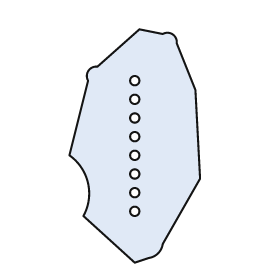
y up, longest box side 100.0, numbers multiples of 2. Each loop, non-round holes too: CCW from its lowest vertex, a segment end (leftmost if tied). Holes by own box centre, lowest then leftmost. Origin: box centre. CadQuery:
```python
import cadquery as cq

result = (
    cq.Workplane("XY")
    .moveTo(0.0, -50.0)
    .lineTo(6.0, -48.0)
    .threePointArc((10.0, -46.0), (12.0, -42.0))
    .lineTo(28.0, -14.0)
    .lineTo(26.0, 24.0)
    .lineTo(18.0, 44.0)
    .threePointArc((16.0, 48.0), (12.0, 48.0))
    .lineTo(2.0, 50.0)
    .lineTo(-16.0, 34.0)
    .threePointArc((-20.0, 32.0), (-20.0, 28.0))
    .lineTo(-28.0, -4.0)
    .threePointArc((-20.0, -16.0), (-22.0, -30.0))
    .close()
    .moveTo(0.0, -28.0)
    .circle(2.0)
    .moveTo(0.0, -20.0)
    .circle(2.0)
    .moveTo(0.0, -12.0)
    .circle(2.0)
    .moveTo(0.0, -4.0)
    .circle(2.0)
    .moveTo(0.0, 4.0)
    .circle(2.0)
    .moveTo(0.0, 12.0)
    .circle(2.0)
    .moveTo(0.0, 20.0)
    .circle(2.0)
    .moveTo(0.0, 28.0)
    .circle(2.0)
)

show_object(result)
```